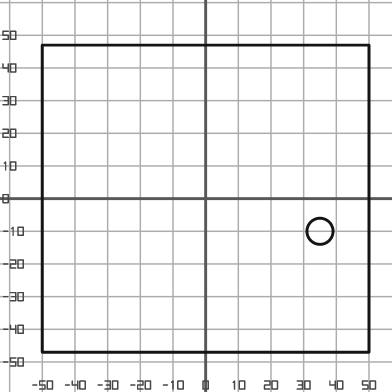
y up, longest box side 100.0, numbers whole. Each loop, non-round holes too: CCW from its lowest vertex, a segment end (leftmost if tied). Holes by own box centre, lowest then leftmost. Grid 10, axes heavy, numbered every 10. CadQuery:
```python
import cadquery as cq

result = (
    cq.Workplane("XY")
    .moveTo(-50.0, -47.0)
    .lineTo(50.0, -47.0)
    .lineTo(50.0, 47.0)
    .lineTo(-50.0, 47.0)
    .close()
    .moveTo(35.0, -10.0)
    .circle(4.0)
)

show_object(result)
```